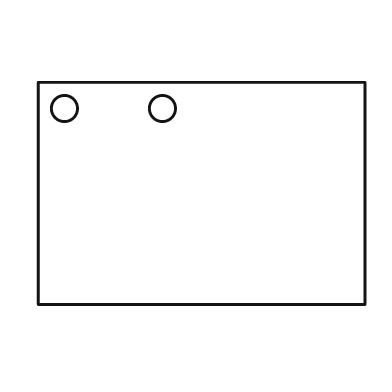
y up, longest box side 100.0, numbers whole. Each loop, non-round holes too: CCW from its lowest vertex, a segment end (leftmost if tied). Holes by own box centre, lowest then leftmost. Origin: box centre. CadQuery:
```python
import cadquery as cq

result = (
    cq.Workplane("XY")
    .moveTo(-50.0, -34.0)
    .lineTo(50.0, -34.0)
    .lineTo(50.0, 34.0)
    .lineTo(-50.0, 34.0)
    .close()
    .moveTo(-42.0, 26.0)
    .circle(4.0)
    .moveTo(-12.0, 26.0)
    .circle(4.0)
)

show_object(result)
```